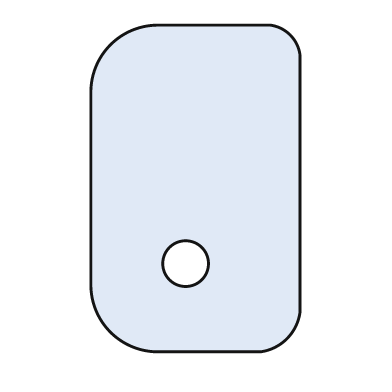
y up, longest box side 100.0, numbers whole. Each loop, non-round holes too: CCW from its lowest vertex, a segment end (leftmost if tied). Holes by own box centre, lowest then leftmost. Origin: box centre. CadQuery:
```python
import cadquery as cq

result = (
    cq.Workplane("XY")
    .moveTo(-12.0, -50.0)
    .lineTo(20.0, -50.0)
    .threePointArc((28.0, -46.0), (32.0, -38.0))
    .lineTo(32.0, 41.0)
    .threePointArc((29.0, 47.0), (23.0, 50.0))
    .lineTo(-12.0, 50.0)
    .threePointArc((-26.0, 44.0), (-32.0, 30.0))
    .lineTo(-32.0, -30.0)
    .threePointArc((-26.0, -44.0), (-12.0, -50.0))
    .close()
    .moveTo(-3.0, -23.0)
    .circle(7.0)
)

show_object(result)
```